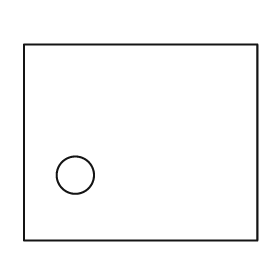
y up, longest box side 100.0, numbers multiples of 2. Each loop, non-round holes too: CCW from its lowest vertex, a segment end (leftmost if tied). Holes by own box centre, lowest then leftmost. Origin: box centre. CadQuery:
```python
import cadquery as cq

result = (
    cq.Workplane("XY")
    .moveTo(-50.0, -42.0)
    .lineTo(50.0, -42.0)
    .lineTo(50.0, 42.0)
    .lineTo(-50.0, 42.0)
    .close()
    .moveTo(-28.0, -14.0)
    .circle(8.0)
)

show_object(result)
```